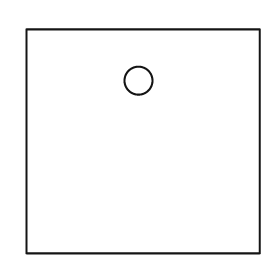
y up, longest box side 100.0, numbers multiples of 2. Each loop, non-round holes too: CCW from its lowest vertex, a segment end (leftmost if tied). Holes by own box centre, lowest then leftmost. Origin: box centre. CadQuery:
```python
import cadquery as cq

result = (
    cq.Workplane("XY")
    .moveTo(-50.0, -48.0)
    .lineTo(50.0, -48.0)
    .lineTo(50.0, 48.0)
    .lineTo(-50.0, 48.0)
    .close()
    .moveTo(-2.0, 26.0)
    .circle(6.0)
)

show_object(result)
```